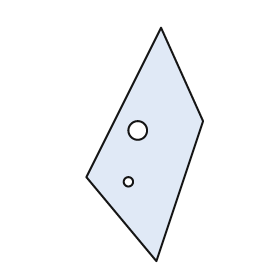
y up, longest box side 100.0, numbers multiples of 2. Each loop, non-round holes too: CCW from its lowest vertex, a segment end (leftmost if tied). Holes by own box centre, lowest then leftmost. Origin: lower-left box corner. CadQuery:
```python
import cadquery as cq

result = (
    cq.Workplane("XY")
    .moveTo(30.0, 0.0)
    .lineTo(50.0, 60.0)
    .lineTo(32.0, 100.0)
    .lineTo(0.0, 36.0)
    .close()
    .moveTo(18.0, 34.0)
    .circle(2.0)
    .moveTo(22.0, 56.0)
    .circle(4.0)
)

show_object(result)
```